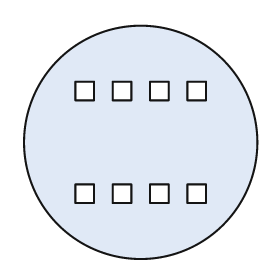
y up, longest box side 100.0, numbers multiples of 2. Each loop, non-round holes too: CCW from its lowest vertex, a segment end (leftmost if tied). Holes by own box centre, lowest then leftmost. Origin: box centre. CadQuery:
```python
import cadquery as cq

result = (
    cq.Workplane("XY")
    .moveTo(0.0, 0.0)
    .circle(50.0)
    .moveTo(-28.0, -26.0)
    .lineTo(-20.0, -26.0)
    .lineTo(-20.0, -18.0)
    .lineTo(-28.0, -18.0)
    .close()
    .moveTo(-12.0, -26.0)
    .lineTo(-4.0, -26.0)
    .lineTo(-4.0, -18.0)
    .lineTo(-12.0, -18.0)
    .close()
    .moveTo(4.0, -26.0)
    .lineTo(12.0, -26.0)
    .lineTo(12.0, -18.0)
    .lineTo(4.0, -18.0)
    .close()
    .moveTo(20.0, -26.0)
    .lineTo(28.0, -26.0)
    .lineTo(28.0, -18.0)
    .lineTo(20.0, -18.0)
    .close()
    .moveTo(-28.0, 18.0)
    .lineTo(-20.0, 18.0)
    .lineTo(-20.0, 26.0)
    .lineTo(-28.0, 26.0)
    .close()
    .moveTo(-12.0, 18.0)
    .lineTo(-4.0, 18.0)
    .lineTo(-4.0, 26.0)
    .lineTo(-12.0, 26.0)
    .close()
    .moveTo(4.0, 18.0)
    .lineTo(12.0, 18.0)
    .lineTo(12.0, 26.0)
    .lineTo(4.0, 26.0)
    .close()
    .moveTo(20.0, 18.0)
    .lineTo(28.0, 18.0)
    .lineTo(28.0, 26.0)
    .lineTo(20.0, 26.0)
    .close()
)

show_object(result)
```